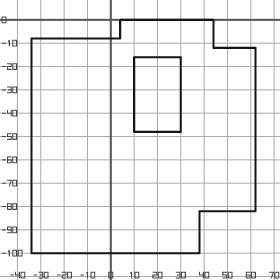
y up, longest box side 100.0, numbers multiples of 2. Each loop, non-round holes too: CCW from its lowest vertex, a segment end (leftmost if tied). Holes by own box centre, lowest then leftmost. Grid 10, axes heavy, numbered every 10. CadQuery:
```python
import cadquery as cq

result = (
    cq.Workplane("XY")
    .moveTo(-34.0, -100.0)
    .lineTo(38.0, -100.0)
    .lineTo(38.0, -82.0)
    .lineTo(62.0, -82.0)
    .lineTo(62.0, -12.0)
    .lineTo(44.0, -12.0)
    .lineTo(44.0, 0.0)
    .lineTo(4.0, 0.0)
    .lineTo(4.0, -8.0)
    .lineTo(-34.0, -8.0)
    .close()
    .moveTo(10.0, -48.0)
    .lineTo(30.0, -48.0)
    .lineTo(30.0, -16.0)
    .lineTo(10.0, -16.0)
    .close()
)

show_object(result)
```